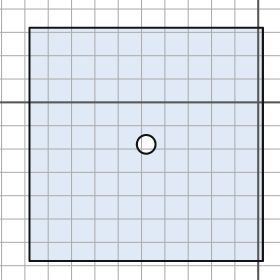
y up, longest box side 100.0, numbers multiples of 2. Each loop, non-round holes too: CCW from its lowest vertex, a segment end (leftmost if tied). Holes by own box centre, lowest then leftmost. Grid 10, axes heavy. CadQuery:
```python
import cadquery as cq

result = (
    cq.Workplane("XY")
    .moveTo(-98.0, -68.0)
    .lineTo(2.0, -68.0)
    .lineTo(2.0, 32.0)
    .lineTo(-98.0, 32.0)
    .close()
    .moveTo(-48.0, -18.0)
    .circle(4.0)
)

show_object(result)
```